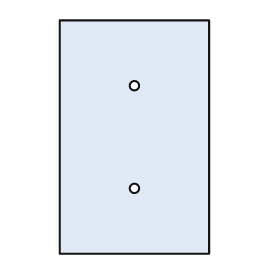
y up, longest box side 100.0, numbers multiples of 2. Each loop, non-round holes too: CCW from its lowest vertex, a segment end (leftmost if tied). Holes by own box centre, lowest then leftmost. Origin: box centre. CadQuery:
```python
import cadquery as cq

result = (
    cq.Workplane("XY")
    .moveTo(-32.0, -50.0)
    .lineTo(32.0, -50.0)
    .lineTo(32.0, 50.0)
    .lineTo(-32.0, 50.0)
    .close()
    .moveTo(0.0, -22.0)
    .circle(2.0)
    .moveTo(0.0, 22.0)
    .circle(2.0)
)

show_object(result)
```